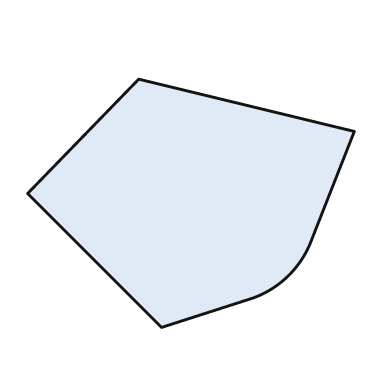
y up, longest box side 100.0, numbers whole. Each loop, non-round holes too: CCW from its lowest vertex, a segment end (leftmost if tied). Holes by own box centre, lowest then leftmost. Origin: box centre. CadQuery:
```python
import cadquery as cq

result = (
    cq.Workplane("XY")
    .moveTo(-9.0, -38.0)
    .lineTo(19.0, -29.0)
    .threePointArc((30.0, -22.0), (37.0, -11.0))
    .lineTo(50.0, 22.0)
    .lineTo(-16.0, 38.0)
    .lineTo(-50.0, 3.0)
    .close()
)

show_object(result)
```